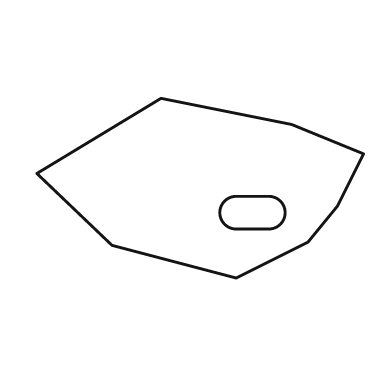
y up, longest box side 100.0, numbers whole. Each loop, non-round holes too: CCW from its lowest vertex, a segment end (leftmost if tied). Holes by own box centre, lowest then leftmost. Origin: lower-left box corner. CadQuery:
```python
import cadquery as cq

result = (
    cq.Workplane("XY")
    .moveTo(61.0, 0.0)
    .lineTo(83.0, 11.0)
    .lineTo(92.0, 22.0)
    .lineTo(100.0, 38.0)
    .lineTo(78.0, 47.0)
    .lineTo(38.0, 55.0)
    .lineTo(0.0, 32.0)
    .lineTo(23.0, 10.0)
    .close()
    .moveTo(61.0, 15.0)
    .lineTo(71.0, 15.0)
    .threePointArc((76.0, 20.0), (71.0, 25.0))
    .lineTo(61.0, 25.0)
    .threePointArc((56.0, 20.0), (61.0, 15.0))
    .close()
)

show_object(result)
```